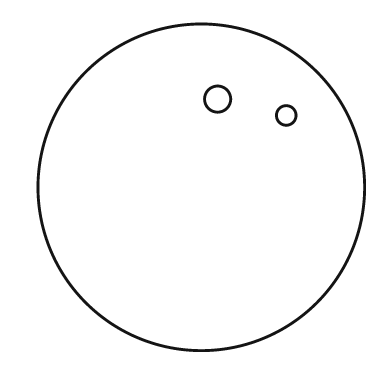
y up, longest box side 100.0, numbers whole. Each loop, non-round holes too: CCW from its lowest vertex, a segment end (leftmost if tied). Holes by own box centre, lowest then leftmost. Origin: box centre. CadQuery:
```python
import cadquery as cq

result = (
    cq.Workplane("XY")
    .moveTo(0.0, 0.0)
    .circle(50.0)
    .moveTo(26.0, 22.0)
    .circle(3.0)
    .moveTo(5.0, 27.0)
    .circle(4.0)
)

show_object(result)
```